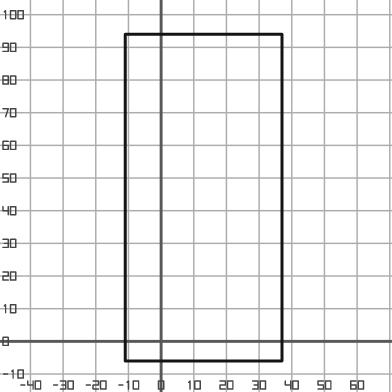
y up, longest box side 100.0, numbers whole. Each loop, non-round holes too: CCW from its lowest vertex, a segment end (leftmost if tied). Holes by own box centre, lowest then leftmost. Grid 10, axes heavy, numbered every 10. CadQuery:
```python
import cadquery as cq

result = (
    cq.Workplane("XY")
    .moveTo(-11.0, -6.0)
    .lineTo(37.0, -6.0)
    .lineTo(37.0, 94.0)
    .lineTo(-11.0, 94.0)
    .close()
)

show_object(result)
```